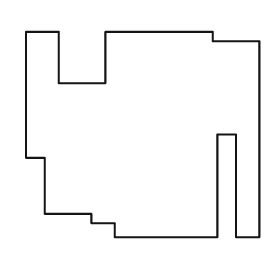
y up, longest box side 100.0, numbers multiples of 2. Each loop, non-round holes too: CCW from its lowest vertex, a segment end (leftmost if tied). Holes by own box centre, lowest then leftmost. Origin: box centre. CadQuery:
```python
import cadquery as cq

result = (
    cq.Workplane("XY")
    .moveTo(-12.0, -44.0)
    .lineTo(32.0, -44.0)
    .lineTo(32.0, 0.0)
    .lineTo(40.0, 0.0)
    .lineTo(40.0, -44.0)
    .lineTo(50.0, -44.0)
    .lineTo(50.0, 40.0)
    .lineTo(30.0, 40.0)
    .lineTo(30.0, 44.0)
    .lineTo(-16.0, 44.0)
    .lineTo(-16.0, 22.0)
    .lineTo(-36.0, 22.0)
    .lineTo(-36.0, 44.0)
    .lineTo(-50.0, 44.0)
    .lineTo(-50.0, -10.0)
    .lineTo(-42.0, -10.0)
    .lineTo(-42.0, -34.0)
    .lineTo(-22.0, -34.0)
    .lineTo(-22.0, -38.0)
    .lineTo(-12.0, -38.0)
    .close()
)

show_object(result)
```